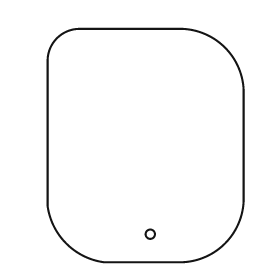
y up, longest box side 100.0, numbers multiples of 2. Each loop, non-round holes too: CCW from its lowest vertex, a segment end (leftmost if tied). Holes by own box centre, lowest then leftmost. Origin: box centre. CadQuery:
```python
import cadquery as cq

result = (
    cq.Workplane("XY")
    .moveTo(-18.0, -50.0)
    .lineTo(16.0, -50.0)
    .threePointArc((34.0, -42.0), (42.0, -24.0))
    .lineTo(42.0, 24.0)
    .threePointArc((34.0, 42.0), (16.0, 50.0))
    .lineTo(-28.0, 50.0)
    .threePointArc((-38.0, 46.0), (-42.0, 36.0))
    .lineTo(-42.0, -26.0)
    .threePointArc((-34.0, -42.0), (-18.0, -50.0))
    .close()
    .moveTo(2.0, -38.0)
    .circle(2.0)
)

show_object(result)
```